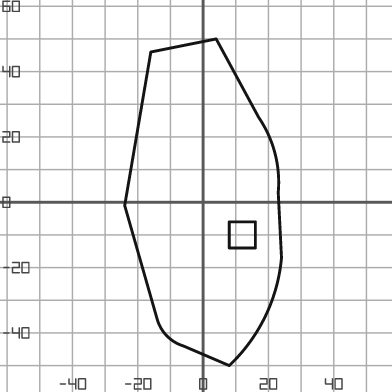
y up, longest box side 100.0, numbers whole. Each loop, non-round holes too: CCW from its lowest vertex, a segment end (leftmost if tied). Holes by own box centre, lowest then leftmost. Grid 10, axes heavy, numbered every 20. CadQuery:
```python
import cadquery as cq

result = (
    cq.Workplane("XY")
    .moveTo(8.0, -50.0)
    .threePointArc((19.0, -35.0), (24.0, -17.0))
    .lineTo(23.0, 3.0)
    .threePointArc((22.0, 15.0), (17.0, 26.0))
    .lineTo(4.0, 50.0)
    .lineTo(-16.0, 46.0)
    .lineTo(-24.0, -1.0)
    .lineTo(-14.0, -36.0)
    .threePointArc((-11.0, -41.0), (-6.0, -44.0))
    .close()
    .moveTo(8.0, -14.0)
    .lineTo(16.0, -14.0)
    .lineTo(16.0, -6.0)
    .lineTo(8.0, -6.0)
    .close()
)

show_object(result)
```